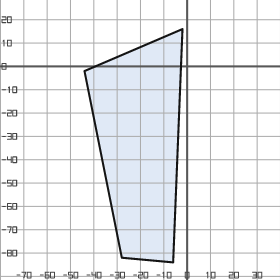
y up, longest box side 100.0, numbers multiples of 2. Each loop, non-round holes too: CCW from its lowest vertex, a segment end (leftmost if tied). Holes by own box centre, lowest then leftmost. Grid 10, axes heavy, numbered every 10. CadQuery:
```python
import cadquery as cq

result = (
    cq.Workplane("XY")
    .moveTo(-6.0, -84.0)
    .lineTo(-2.0, 16.0)
    .lineTo(-44.0, -2.0)
    .lineTo(-28.0, -82.0)
    .close()
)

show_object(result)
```